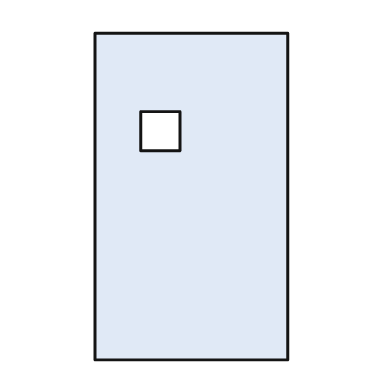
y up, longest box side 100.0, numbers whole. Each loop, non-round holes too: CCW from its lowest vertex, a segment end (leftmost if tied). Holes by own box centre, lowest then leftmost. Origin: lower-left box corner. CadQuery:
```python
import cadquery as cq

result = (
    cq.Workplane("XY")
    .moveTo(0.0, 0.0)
    .lineTo(59.0, 0.0)
    .lineTo(59.0, 100.0)
    .lineTo(0.0, 100.0)
    .close()
    .moveTo(14.0, 64.0)
    .lineTo(26.0, 64.0)
    .lineTo(26.0, 76.0)
    .lineTo(14.0, 76.0)
    .close()
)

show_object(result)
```